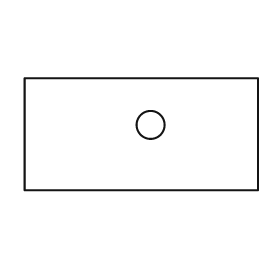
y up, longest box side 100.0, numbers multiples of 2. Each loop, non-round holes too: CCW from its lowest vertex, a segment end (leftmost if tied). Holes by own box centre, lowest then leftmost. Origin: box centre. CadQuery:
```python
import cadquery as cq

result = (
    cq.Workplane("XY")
    .moveTo(-50.0, -24.0)
    .lineTo(50.0, -24.0)
    .lineTo(50.0, 24.0)
    .lineTo(-50.0, 24.0)
    .close()
    .moveTo(4.0, 4.0)
    .circle(6.0)
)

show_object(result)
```